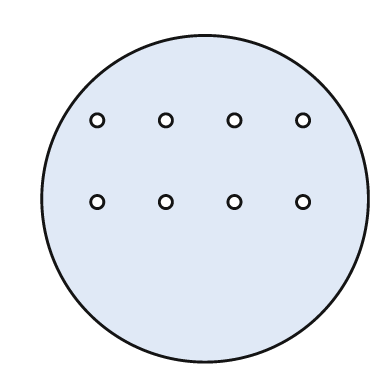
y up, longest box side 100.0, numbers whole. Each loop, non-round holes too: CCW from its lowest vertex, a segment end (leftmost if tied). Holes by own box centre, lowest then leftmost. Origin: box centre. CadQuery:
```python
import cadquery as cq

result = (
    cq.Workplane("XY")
    .moveTo(0.0, 0.0)
    .circle(50.0)
    .moveTo(-33.0, -1.0)
    .circle(2.0)
    .moveTo(-12.0, -1.0)
    .circle(2.0)
    .moveTo(9.0, -1.0)
    .circle(2.0)
    .moveTo(30.0, -1.0)
    .circle(2.0)
    .moveTo(-33.0, 24.0)
    .circle(2.0)
    .moveTo(-12.0, 24.0)
    .circle(2.0)
    .moveTo(9.0, 24.0)
    .circle(2.0)
    .moveTo(30.0, 24.0)
    .circle(2.0)
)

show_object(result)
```